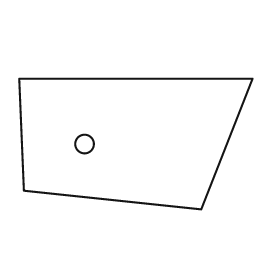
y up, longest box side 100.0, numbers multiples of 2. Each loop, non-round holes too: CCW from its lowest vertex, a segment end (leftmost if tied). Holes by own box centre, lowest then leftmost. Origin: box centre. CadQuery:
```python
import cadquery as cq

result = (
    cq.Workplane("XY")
    .moveTo(28.0, -28.0)
    .lineTo(50.0, 28.0)
    .lineTo(-50.0, 28.0)
    .lineTo(-48.0, -20.0)
    .close()
    .moveTo(-22.0, 0.0)
    .circle(4.0)
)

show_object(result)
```